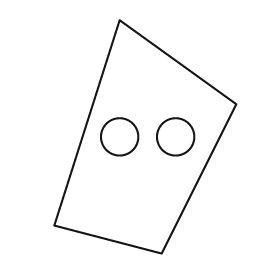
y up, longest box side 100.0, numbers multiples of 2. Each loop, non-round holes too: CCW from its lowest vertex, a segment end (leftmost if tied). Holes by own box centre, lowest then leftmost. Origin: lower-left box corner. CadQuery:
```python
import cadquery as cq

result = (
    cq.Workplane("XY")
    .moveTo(46.0, 0.0)
    .lineTo(78.0, 64.0)
    .lineTo(28.0, 100.0)
    .lineTo(0.0, 12.0)
    .close()
    .moveTo(28.0, 50.0)
    .circle(8.0)
    .moveTo(52.0, 50.0)
    .circle(8.0)
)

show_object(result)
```